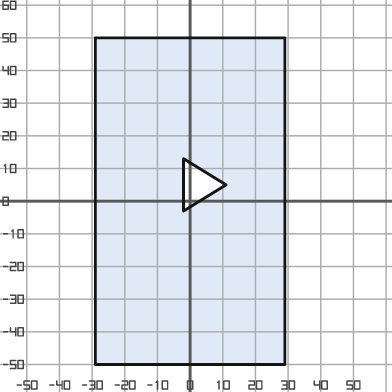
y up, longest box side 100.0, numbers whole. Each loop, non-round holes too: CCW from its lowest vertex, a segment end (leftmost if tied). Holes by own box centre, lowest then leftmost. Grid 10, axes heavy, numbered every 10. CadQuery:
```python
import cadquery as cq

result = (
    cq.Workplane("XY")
    .moveTo(-29.0, -50.0)
    .lineTo(29.0, -50.0)
    .lineTo(29.0, 50.0)
    .lineTo(-29.0, 50.0)
    .close()
    .moveTo(-2.0, -3.0)
    .lineTo(11.0, 5.0)
    .lineTo(-2.0, 13.0)
    .close()
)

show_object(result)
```